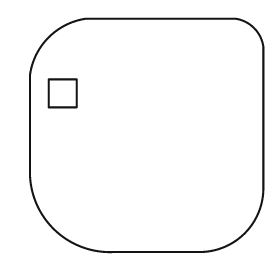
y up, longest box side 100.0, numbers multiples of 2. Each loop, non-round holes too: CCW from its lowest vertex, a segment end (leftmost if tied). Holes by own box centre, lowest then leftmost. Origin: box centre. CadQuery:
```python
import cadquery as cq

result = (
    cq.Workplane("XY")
    .moveTo(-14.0, -50.0)
    .lineTo(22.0, -50.0)
    .threePointArc((42.0, -42.0), (50.0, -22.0))
    .lineTo(50.0, 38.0)
    .threePointArc((46.0, 46.0), (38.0, 50.0))
    .lineTo(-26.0, 50.0)
    .threePointArc((-42.0, 42.0), (-50.0, 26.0))
    .lineTo(-50.0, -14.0)
    .threePointArc((-40.0, -40.0), (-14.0, -50.0))
    .close()
    .moveTo(-42.0, 12.0)
    .lineTo(-30.0, 12.0)
    .lineTo(-30.0, 24.0)
    .lineTo(-42.0, 24.0)
    .close()
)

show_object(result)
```